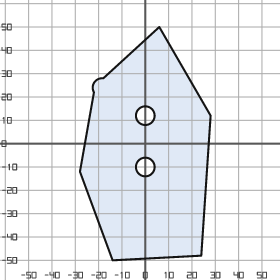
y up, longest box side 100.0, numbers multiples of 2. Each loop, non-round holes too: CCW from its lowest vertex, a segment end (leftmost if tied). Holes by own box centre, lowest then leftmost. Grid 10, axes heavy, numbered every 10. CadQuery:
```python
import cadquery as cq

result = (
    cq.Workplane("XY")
    .moveTo(-14.0, -50.0)
    .lineTo(24.0, -48.0)
    .lineTo(28.0, 12.0)
    .lineTo(6.0, 50.0)
    .lineTo(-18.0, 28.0)
    .threePointArc((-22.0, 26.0), (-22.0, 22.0))
    .lineTo(-28.0, -12.0)
    .close()
    .moveTo(0.0, -10.0)
    .circle(4.0)
    .moveTo(0.0, 12.0)
    .circle(4.0)
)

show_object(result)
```